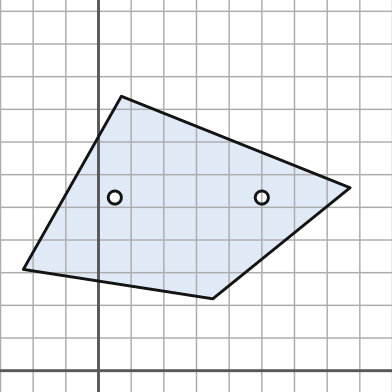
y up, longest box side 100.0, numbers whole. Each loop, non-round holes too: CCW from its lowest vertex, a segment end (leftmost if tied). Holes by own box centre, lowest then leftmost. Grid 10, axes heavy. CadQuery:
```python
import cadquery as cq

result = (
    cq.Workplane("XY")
    .moveTo(35.0, 22.0)
    .lineTo(77.0, 56.0)
    .lineTo(7.0, 84.0)
    .lineTo(-23.0, 31.0)
    .close()
    .moveTo(5.0, 53.0)
    .circle(2.0)
    .moveTo(50.0, 53.0)
    .circle(2.0)
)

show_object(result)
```